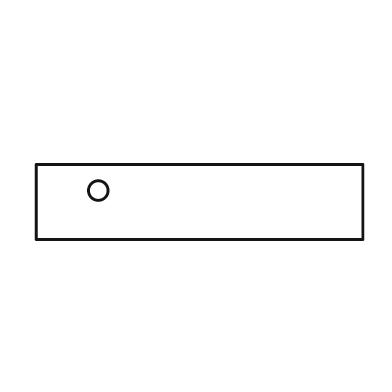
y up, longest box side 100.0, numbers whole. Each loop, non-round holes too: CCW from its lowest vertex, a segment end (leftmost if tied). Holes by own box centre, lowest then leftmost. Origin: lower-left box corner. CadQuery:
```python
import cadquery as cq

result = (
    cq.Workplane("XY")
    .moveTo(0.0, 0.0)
    .lineTo(100.0, 0.0)
    .lineTo(100.0, 23.0)
    .lineTo(0.0, 23.0)
    .close()
    .moveTo(19.0, 15.0)
    .circle(3.0)
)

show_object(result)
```